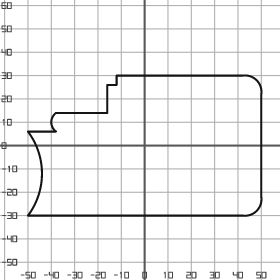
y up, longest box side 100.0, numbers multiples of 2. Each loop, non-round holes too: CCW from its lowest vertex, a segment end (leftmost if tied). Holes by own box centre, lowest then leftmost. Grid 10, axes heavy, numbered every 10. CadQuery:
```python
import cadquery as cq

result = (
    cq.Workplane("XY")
    .moveTo(-50.0, -30.0)
    .lineTo(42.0, -30.0)
    .threePointArc((48.0, -28.0), (50.0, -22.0))
    .lineTo(50.0, 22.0)
    .threePointArc((48.0, 28.0), (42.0, 30.0))
    .lineTo(-12.0, 30.0)
    .lineTo(-12.0, 26.0)
    .lineTo(-16.0, 26.0)
    .lineTo(-16.0, 14.0)
    .lineTo(-38.0, 14.0)
    .threePointArc((-40.0, 10.0), (-38.0, 6.0))
    .lineTo(-50.0, 6.0)
    .threePointArc((-44.0, -12.0), (-50.0, -30.0))
    .close()
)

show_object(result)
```